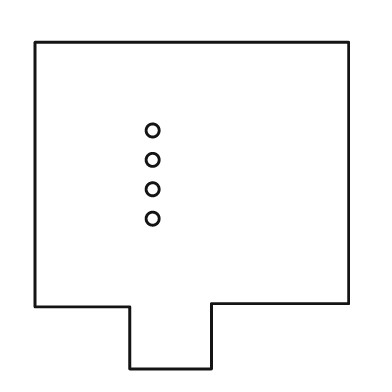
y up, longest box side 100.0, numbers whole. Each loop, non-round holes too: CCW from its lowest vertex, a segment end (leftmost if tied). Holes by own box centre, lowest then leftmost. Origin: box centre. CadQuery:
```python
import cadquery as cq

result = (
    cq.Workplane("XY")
    .moveTo(-19.0, -50.0)
    .lineTo(6.0, -50.0)
    .lineTo(6.0, -30.0)
    .lineTo(48.0, -30.0)
    .lineTo(48.0, 50.0)
    .lineTo(-48.0, 50.0)
    .lineTo(-48.0, -31.0)
    .lineTo(-19.0, -31.0)
    .close()
    .moveTo(-12.0, -4.0)
    .circle(2.0)
    .moveTo(-12.0, 5.0)
    .circle(2.0)
    .moveTo(-12.0, 14.0)
    .circle(2.0)
    .moveTo(-12.0, 23.0)
    .circle(2.0)
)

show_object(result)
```